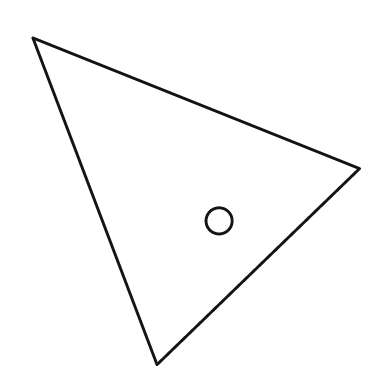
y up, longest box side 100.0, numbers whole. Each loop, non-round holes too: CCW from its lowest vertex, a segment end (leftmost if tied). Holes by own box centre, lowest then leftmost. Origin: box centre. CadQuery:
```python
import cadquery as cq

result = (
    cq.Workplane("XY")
    .moveTo(-12.0, -50.0)
    .lineTo(50.0, 10.0)
    .lineTo(-50.0, 50.0)
    .close()
    .moveTo(7.0, -6.0)
    .circle(4.0)
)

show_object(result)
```